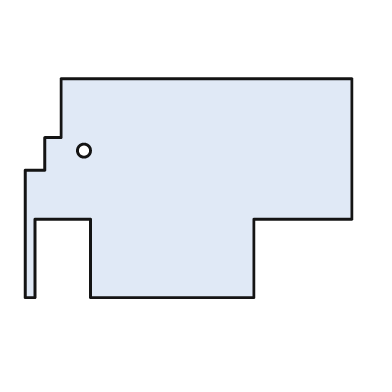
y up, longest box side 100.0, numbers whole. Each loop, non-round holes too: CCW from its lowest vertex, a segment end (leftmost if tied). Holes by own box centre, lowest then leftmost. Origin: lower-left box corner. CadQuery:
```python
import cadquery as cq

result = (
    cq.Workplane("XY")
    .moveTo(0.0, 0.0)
    .lineTo(3.0, 0.0)
    .lineTo(3.0, 24.0)
    .lineTo(20.0, 24.0)
    .lineTo(20.0, 0.0)
    .lineTo(70.0, 0.0)
    .lineTo(70.0, 24.0)
    .lineTo(100.0, 24.0)
    .lineTo(100.0, 67.0)
    .lineTo(11.0, 67.0)
    .lineTo(11.0, 49.0)
    .lineTo(6.0, 49.0)
    .lineTo(6.0, 39.0)
    .lineTo(0.0, 39.0)
    .close()
    .moveTo(18.0, 45.0)
    .circle(2.0)
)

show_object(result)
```